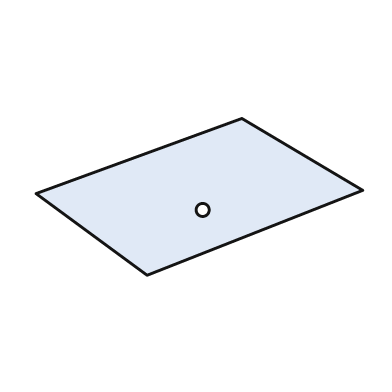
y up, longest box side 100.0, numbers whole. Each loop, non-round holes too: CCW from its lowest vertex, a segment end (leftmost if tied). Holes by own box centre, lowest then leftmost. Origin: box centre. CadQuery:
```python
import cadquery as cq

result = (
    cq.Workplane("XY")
    .moveTo(-16.0, -24.0)
    .lineTo(50.0, 2.0)
    .lineTo(13.0, 24.0)
    .lineTo(-50.0, 1.0)
    .close()
    .moveTo(1.0, -4.0)
    .circle(2.0)
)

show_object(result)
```